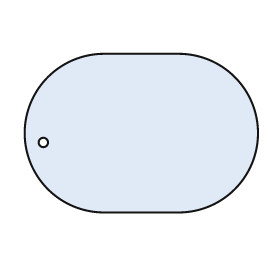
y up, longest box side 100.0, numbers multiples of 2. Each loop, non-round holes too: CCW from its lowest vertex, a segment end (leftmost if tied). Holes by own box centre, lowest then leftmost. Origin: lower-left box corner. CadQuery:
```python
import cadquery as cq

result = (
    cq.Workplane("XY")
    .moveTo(34.0, 0.0)
    .lineTo(66.0, 0.0)
    .threePointArc((100.0, 34.0), (66.0, 68.0))
    .lineTo(34.0, 68.0)
    .threePointArc((0.0, 34.0), (34.0, 0.0))
    .close()
    .moveTo(8.0, 30.0)
    .circle(2.0)
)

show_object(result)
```